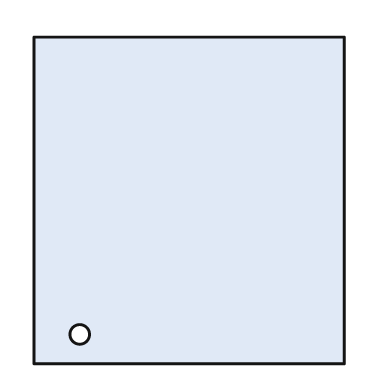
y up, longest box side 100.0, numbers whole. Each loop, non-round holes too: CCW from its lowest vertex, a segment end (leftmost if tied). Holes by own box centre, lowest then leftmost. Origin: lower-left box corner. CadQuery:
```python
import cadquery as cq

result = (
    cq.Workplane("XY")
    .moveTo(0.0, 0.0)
    .lineTo(95.0, 0.0)
    .lineTo(95.0, 100.0)
    .lineTo(0.0, 100.0)
    .close()
    .moveTo(14.0, 9.0)
    .circle(3.0)
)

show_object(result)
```